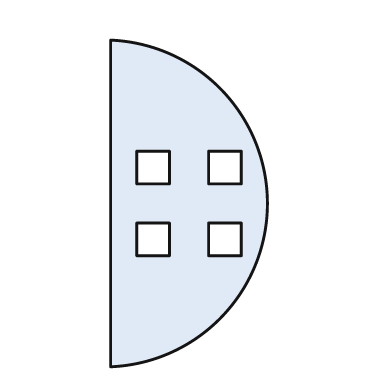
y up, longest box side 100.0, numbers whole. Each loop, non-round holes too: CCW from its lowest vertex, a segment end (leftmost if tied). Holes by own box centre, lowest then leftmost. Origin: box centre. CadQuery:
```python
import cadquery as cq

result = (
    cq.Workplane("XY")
    .moveTo(-24.0, -50.0)
    .threePointArc((24.0, 0.0), (-24.0, 50.0))
    .close()
    .moveTo(-16.0, -16.0)
    .lineTo(-6.0, -16.0)
    .lineTo(-6.0, -6.0)
    .lineTo(-16.0, -6.0)
    .close()
    .moveTo(6.0, -16.0)
    .lineTo(16.0, -16.0)
    .lineTo(16.0, -6.0)
    .lineTo(6.0, -6.0)
    .close()
    .moveTo(-16.0, 6.0)
    .lineTo(-6.0, 6.0)
    .lineTo(-6.0, 16.0)
    .lineTo(-16.0, 16.0)
    .close()
    .moveTo(6.0, 6.0)
    .lineTo(16.0, 6.0)
    .lineTo(16.0, 16.0)
    .lineTo(6.0, 16.0)
    .close()
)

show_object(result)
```